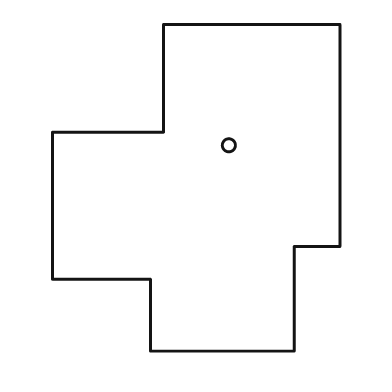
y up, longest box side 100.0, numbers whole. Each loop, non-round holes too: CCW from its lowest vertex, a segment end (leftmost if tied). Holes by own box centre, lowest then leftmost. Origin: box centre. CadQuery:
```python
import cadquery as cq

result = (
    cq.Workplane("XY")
    .moveTo(-14.0, -50.0)
    .lineTo(30.0, -50.0)
    .lineTo(30.0, -18.0)
    .lineTo(44.0, -18.0)
    .lineTo(44.0, 50.0)
    .lineTo(-10.0, 50.0)
    .lineTo(-10.0, 17.0)
    .lineTo(-44.0, 17.0)
    .lineTo(-44.0, -28.0)
    .lineTo(-14.0, -28.0)
    .close()
    .moveTo(10.0, 13.0)
    .circle(2.0)
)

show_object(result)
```